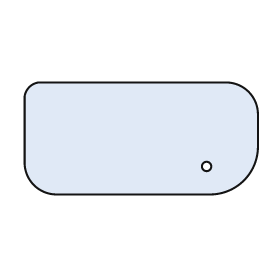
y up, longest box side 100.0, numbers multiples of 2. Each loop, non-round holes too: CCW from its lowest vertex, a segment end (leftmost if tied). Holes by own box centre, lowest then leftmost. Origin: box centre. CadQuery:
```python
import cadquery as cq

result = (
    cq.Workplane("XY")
    .moveTo(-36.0, -24.0)
    .lineTo(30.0, -24.0)
    .threePointArc((44.0, -18.0), (50.0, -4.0))
    .lineTo(50.0, 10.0)
    .threePointArc((46.0, 20.0), (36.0, 24.0))
    .lineTo(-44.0, 24.0)
    .threePointArc((-48.0, 22.0), (-50.0, 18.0))
    .lineTo(-50.0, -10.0)
    .threePointArc((-46.0, -20.0), (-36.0, -24.0))
    .close()
    .moveTo(28.0, -12.0)
    .circle(2.0)
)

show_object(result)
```